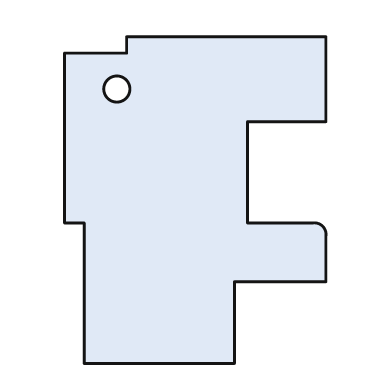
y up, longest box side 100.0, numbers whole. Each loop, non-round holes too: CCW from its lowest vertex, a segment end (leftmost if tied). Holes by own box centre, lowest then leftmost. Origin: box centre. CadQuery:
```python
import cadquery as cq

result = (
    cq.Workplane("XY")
    .moveTo(-34.0, -50.0)
    .lineTo(12.0, -50.0)
    .lineTo(12.0, -25.0)
    .lineTo(40.0, -25.0)
    .lineTo(40.0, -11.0)
    .threePointArc((39.0, -8.0), (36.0, -7.0))
    .lineTo(16.0, -7.0)
    .lineTo(16.0, 24.0)
    .lineTo(40.0, 24.0)
    .lineTo(40.0, 50.0)
    .lineTo(-21.0, 50.0)
    .lineTo(-21.0, 45.0)
    .lineTo(-40.0, 45.0)
    .lineTo(-40.0, -7.0)
    .lineTo(-34.0, -7.0)
    .close()
    .moveTo(-24.0, 34.0)
    .circle(4.0)
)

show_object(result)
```